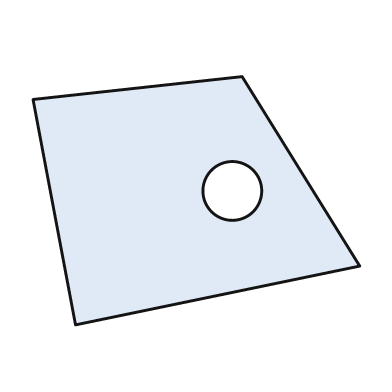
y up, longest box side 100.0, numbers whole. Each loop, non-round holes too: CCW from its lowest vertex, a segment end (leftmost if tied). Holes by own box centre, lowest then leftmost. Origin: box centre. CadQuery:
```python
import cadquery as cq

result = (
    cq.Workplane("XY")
    .moveTo(-37.0, -38.0)
    .lineTo(50.0, -20.0)
    .lineTo(14.0, 38.0)
    .lineTo(-50.0, 31.0)
    .close()
    .moveTo(11.0, 3.0)
    .circle(9.0)
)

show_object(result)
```